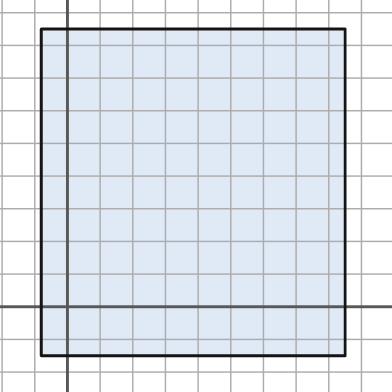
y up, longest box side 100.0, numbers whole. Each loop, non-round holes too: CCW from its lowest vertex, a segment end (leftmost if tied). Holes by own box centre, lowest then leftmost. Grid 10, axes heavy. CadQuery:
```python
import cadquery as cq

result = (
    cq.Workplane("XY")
    .moveTo(-8.0, -15.0)
    .lineTo(85.0, -15.0)
    .lineTo(85.0, 85.0)
    .lineTo(-8.0, 85.0)
    .close()
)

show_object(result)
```